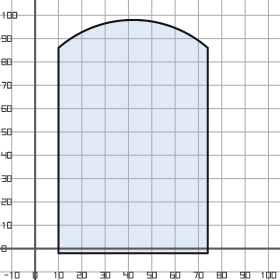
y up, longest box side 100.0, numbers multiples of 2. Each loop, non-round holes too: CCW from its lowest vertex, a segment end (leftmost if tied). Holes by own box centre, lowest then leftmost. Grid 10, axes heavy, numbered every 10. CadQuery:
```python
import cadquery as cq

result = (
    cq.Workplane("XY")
    .moveTo(10.0, -2.0)
    .lineTo(74.0, -2.0)
    .lineTo(74.0, 86.0)
    .threePointArc((42.0, 98.0), (10.0, 86.0))
    .close()
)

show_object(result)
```